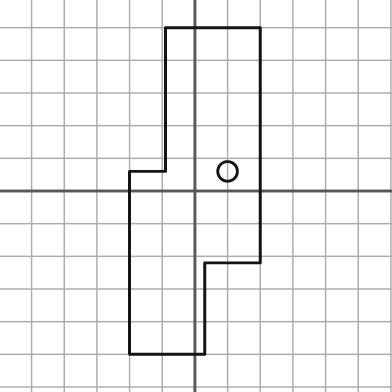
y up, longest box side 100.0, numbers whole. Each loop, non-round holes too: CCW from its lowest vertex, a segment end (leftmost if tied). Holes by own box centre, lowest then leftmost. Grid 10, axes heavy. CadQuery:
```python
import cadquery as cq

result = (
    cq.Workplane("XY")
    .moveTo(-20.0, -50.0)
    .lineTo(3.0, -50.0)
    .lineTo(3.0, -22.0)
    .lineTo(20.0, -22.0)
    .lineTo(20.0, 50.0)
    .lineTo(-9.0, 50.0)
    .lineTo(-9.0, 6.0)
    .lineTo(-20.0, 6.0)
    .close()
    .moveTo(10.0, 6.0)
    .circle(3.0)
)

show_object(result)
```